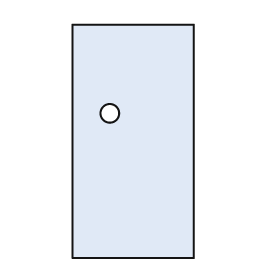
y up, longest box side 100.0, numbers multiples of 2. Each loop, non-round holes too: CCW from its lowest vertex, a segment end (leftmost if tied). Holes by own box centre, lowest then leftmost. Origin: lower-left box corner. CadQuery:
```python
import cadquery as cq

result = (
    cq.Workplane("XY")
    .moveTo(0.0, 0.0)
    .lineTo(52.0, 0.0)
    .lineTo(52.0, 100.0)
    .lineTo(0.0, 100.0)
    .close()
    .moveTo(16.0, 62.0)
    .circle(4.0)
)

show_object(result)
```